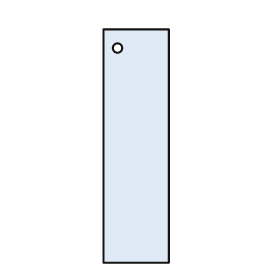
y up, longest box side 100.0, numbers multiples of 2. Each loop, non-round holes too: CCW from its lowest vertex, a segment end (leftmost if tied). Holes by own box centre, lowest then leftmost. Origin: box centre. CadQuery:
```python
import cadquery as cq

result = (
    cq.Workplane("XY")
    .moveTo(-14.0, -50.0)
    .lineTo(14.0, -50.0)
    .lineTo(14.0, 50.0)
    .lineTo(-14.0, 50.0)
    .close()
    .moveTo(-8.0, 42.0)
    .circle(2.0)
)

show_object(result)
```